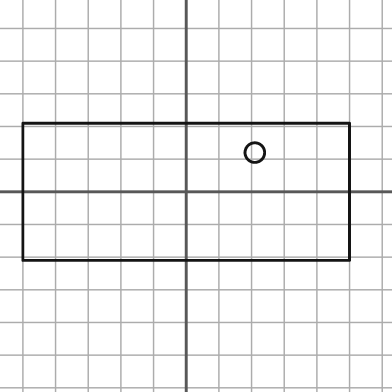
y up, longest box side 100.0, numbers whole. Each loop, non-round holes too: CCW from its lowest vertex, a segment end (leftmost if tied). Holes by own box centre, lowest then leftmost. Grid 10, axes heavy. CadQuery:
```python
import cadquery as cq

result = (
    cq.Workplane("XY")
    .moveTo(-50.0, -21.0)
    .lineTo(50.0, -21.0)
    .lineTo(50.0, 21.0)
    .lineTo(-50.0, 21.0)
    .close()
    .moveTo(21.0, 12.0)
    .circle(3.0)
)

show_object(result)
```